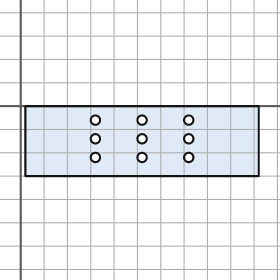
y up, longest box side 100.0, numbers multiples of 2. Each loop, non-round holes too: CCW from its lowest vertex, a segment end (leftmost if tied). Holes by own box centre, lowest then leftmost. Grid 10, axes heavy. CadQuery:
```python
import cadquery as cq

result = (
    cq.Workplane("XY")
    .moveTo(2.0, -30.0)
    .lineTo(102.0, -30.0)
    .lineTo(102.0, 0.0)
    .lineTo(2.0, 0.0)
    .close()
    .moveTo(32.0, -22.0)
    .circle(2.0)
    .moveTo(52.0, -22.0)
    .circle(2.0)
    .moveTo(72.0, -22.0)
    .circle(2.0)
    .moveTo(32.0, -14.0)
    .circle(2.0)
    .moveTo(52.0, -14.0)
    .circle(2.0)
    .moveTo(72.0, -14.0)
    .circle(2.0)
    .moveTo(32.0, -6.0)
    .circle(2.0)
    .moveTo(52.0, -6.0)
    .circle(2.0)
    .moveTo(72.0, -6.0)
    .circle(2.0)
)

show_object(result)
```